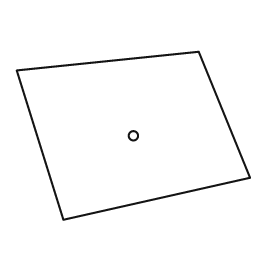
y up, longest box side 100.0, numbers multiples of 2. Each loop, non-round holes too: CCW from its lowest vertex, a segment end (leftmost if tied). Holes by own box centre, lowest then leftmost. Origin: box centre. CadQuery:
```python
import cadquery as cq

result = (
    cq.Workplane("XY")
    .moveTo(-30.0, -36.0)
    .lineTo(50.0, -18.0)
    .lineTo(28.0, 36.0)
    .lineTo(-50.0, 28.0)
    .close()
    .moveTo(0.0, 0.0)
    .circle(2.0)
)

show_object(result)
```